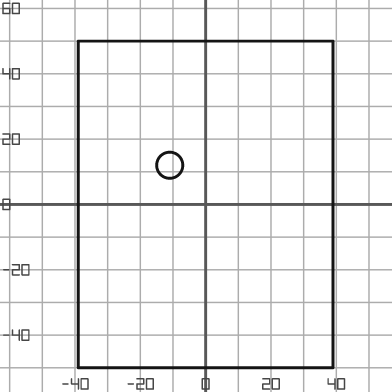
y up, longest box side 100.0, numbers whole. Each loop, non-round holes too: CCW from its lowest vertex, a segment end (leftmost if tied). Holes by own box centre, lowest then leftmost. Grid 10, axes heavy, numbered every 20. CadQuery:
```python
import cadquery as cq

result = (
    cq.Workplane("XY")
    .moveTo(-39.0, -50.0)
    .lineTo(39.0, -50.0)
    .lineTo(39.0, 50.0)
    .lineTo(-39.0, 50.0)
    .close()
    .moveTo(-11.0, 12.0)
    .circle(4.0)
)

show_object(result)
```